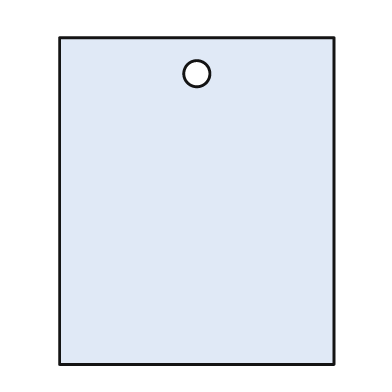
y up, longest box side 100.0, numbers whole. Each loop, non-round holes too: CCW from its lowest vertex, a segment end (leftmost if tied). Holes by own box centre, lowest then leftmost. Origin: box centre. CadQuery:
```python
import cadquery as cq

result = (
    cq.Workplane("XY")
    .moveTo(-42.0, -50.0)
    .lineTo(42.0, -50.0)
    .lineTo(42.0, 50.0)
    .lineTo(-42.0, 50.0)
    .close()
    .moveTo(0.0, 39.0)
    .circle(4.0)
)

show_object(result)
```